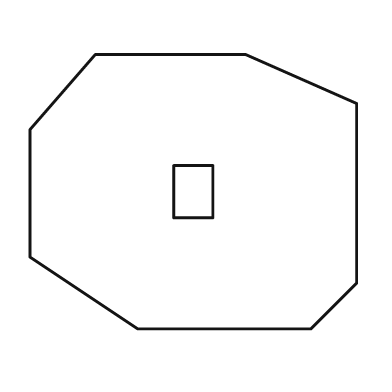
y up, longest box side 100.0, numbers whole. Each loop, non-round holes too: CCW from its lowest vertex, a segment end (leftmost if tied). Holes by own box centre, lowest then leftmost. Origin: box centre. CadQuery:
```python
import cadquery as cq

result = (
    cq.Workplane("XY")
    .moveTo(-17.0, -42.0)
    .lineTo(36.0, -42.0)
    .lineTo(50.0, -28.0)
    .lineTo(50.0, 27.0)
    .lineTo(16.0, 42.0)
    .lineTo(-30.0, 42.0)
    .lineTo(-50.0, 19.0)
    .lineTo(-50.0, -20.0)
    .close()
    .moveTo(-6.0, -8.0)
    .lineTo(6.0, -8.0)
    .lineTo(6.0, 8.0)
    .lineTo(-6.0, 8.0)
    .close()
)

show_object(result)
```